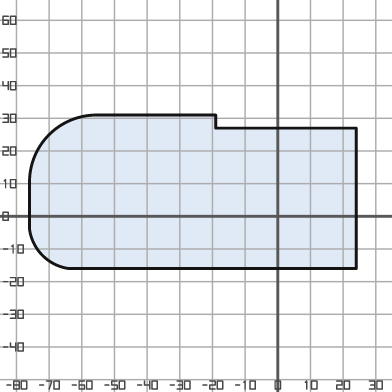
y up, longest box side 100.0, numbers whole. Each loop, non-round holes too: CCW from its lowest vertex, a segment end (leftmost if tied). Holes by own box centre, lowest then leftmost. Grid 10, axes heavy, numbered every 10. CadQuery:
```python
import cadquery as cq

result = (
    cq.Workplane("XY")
    .moveTo(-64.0, -16.0)
    .lineTo(24.0, -16.0)
    .lineTo(24.0, 27.0)
    .lineTo(-19.0, 27.0)
    .lineTo(-19.0, 31.0)
    .lineTo(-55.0, 31.0)
    .threePointArc((-70.0, 25.0), (-76.0, 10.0))
    .lineTo(-76.0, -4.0)
    .threePointArc((-72.0, -12.0), (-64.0, -16.0))
    .close()
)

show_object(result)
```